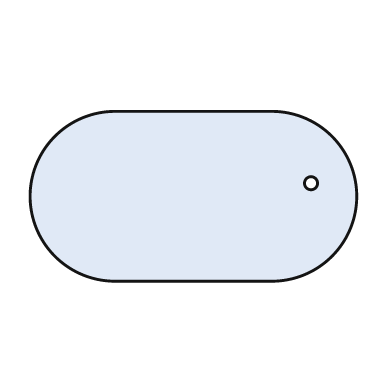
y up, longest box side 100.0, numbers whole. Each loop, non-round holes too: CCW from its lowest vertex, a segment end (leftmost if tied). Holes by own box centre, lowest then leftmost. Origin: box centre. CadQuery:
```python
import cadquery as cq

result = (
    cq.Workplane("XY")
    .moveTo(-24.0, -26.0)
    .lineTo(24.0, -26.0)
    .threePointArc((50.0, 0.0), (24.0, 26.0))
    .lineTo(-24.0, 26.0)
    .threePointArc((-50.0, 0.0), (-24.0, -26.0))
    .close()
    .moveTo(36.0, 4.0)
    .circle(2.0)
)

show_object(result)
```